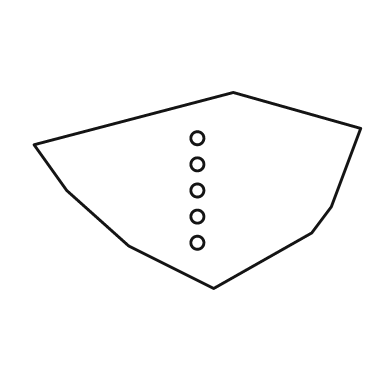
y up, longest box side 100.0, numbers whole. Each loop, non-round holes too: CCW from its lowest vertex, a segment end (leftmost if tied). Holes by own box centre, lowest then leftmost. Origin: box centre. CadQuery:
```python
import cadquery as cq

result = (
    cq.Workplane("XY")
    .moveTo(5.0, -30.0)
    .lineTo(35.0, -13.0)
    .lineTo(41.0, -5.0)
    .lineTo(50.0, 19.0)
    .lineTo(11.0, 30.0)
    .lineTo(-50.0, 14.0)
    .lineTo(-40.0, 0.0)
    .lineTo(-21.0, -17.0)
    .close()
    .moveTo(0.0, -16.0)
    .circle(2.0)
    .moveTo(0.0, -8.0)
    .circle(2.0)
    .moveTo(0.0, 0.0)
    .circle(2.0)
    .moveTo(0.0, 8.0)
    .circle(2.0)
    .moveTo(0.0, 16.0)
    .circle(2.0)
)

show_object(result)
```